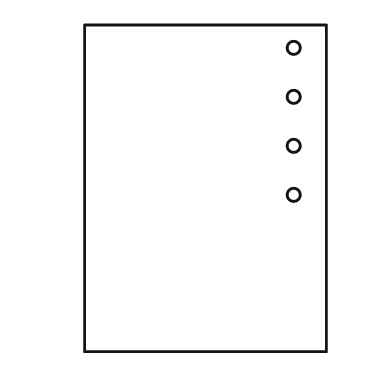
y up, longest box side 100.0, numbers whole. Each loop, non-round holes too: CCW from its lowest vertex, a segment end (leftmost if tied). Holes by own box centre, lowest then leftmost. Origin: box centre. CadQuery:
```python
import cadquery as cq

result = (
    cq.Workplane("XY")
    .moveTo(-37.0, -50.0)
    .lineTo(37.0, -50.0)
    .lineTo(37.0, 50.0)
    .lineTo(-37.0, 50.0)
    .close()
    .moveTo(27.0, -2.0)
    .circle(2.0)
    .moveTo(27.0, 13.0)
    .circle(2.0)
    .moveTo(27.0, 28.0)
    .circle(2.0)
    .moveTo(27.0, 43.0)
    .circle(2.0)
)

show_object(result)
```